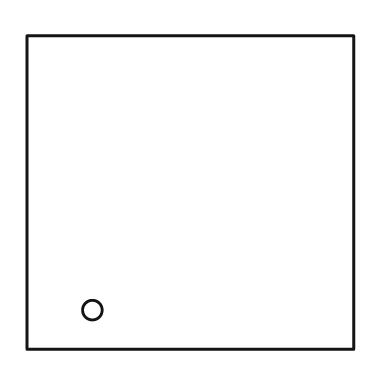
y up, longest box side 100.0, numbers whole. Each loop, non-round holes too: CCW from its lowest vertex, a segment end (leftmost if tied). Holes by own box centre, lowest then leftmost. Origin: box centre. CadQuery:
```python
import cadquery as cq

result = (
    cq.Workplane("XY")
    .moveTo(-50.0, -48.0)
    .lineTo(50.0, -48.0)
    .lineTo(50.0, 48.0)
    .lineTo(-50.0, 48.0)
    .close()
    .moveTo(-30.0, -36.0)
    .circle(3.0)
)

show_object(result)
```